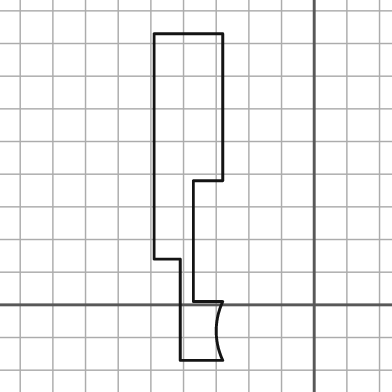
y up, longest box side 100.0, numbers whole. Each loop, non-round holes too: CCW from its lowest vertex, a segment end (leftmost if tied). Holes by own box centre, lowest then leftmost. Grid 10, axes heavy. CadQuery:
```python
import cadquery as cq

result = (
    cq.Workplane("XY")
    .moveTo(-41.0, -17.0)
    .lineTo(-28.0, -17.0)
    .threePointArc((-30.0, -8.0), (-28.0, 1.0))
    .lineTo(-37.0, 1.0)
    .lineTo(-37.0, 38.0)
    .lineTo(-28.0, 38.0)
    .lineTo(-28.0, 83.0)
    .lineTo(-49.0, 83.0)
    .lineTo(-49.0, 14.0)
    .lineTo(-41.0, 14.0)
    .close()
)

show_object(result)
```